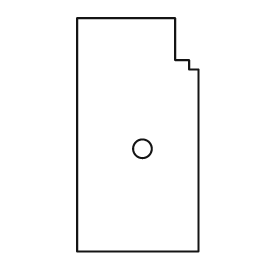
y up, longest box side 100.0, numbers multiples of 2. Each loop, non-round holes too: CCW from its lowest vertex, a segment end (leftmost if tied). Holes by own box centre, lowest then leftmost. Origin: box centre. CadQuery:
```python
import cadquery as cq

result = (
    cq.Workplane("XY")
    .moveTo(-26.0, -50.0)
    .lineTo(26.0, -50.0)
    .lineTo(26.0, 28.0)
    .lineTo(22.0, 28.0)
    .lineTo(22.0, 32.0)
    .lineTo(16.0, 32.0)
    .lineTo(16.0, 50.0)
    .lineTo(-26.0, 50.0)
    .close()
    .moveTo(2.0, -6.0)
    .circle(4.0)
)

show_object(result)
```